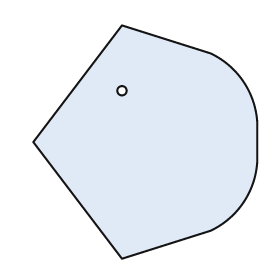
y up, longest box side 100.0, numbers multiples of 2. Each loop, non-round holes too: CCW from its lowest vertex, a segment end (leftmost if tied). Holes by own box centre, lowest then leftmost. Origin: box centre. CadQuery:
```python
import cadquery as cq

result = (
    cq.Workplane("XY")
    .moveTo(-10.0, -50.0)
    .lineTo(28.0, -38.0)
    .threePointArc((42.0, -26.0), (48.0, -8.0))
    .lineTo(48.0, 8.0)
    .threePointArc((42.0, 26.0), (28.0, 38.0))
    .lineTo(-10.0, 50.0)
    .lineTo(-48.0, 0.0)
    .close()
    .moveTo(-10.0, 22.0)
    .circle(2.0)
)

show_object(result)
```